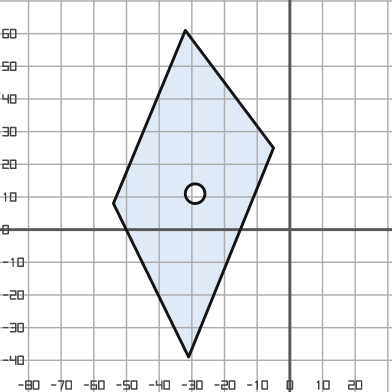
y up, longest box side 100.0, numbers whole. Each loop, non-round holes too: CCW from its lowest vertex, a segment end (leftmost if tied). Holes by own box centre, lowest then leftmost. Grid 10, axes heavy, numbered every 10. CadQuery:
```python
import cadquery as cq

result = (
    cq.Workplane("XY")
    .moveTo(-31.0, -39.0)
    .lineTo(-5.0, 25.0)
    .lineTo(-32.0, 61.0)
    .lineTo(-54.0, 8.0)
    .close()
    .moveTo(-29.0, 11.0)
    .circle(3.0)
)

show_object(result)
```